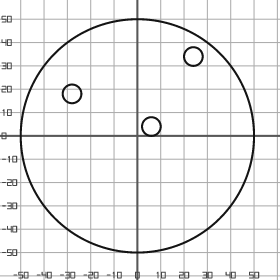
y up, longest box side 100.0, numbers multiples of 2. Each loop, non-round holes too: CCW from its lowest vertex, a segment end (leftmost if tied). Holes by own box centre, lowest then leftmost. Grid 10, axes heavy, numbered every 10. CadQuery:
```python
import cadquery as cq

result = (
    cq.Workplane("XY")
    .moveTo(0.0, 0.0)
    .circle(50.0)
    .moveTo(6.0, 4.0)
    .circle(4.0)
    .moveTo(-28.0, 18.0)
    .circle(4.0)
    .moveTo(24.0, 34.0)
    .circle(4.0)
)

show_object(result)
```